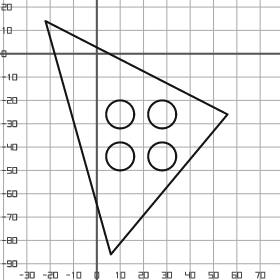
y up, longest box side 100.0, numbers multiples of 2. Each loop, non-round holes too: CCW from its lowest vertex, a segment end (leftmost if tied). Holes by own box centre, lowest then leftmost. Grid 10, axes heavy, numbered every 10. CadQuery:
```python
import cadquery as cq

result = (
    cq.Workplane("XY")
    .moveTo(6.0, -86.0)
    .lineTo(56.0, -26.0)
    .lineTo(-22.0, 14.0)
    .close()
    .moveTo(10.0, -44.0)
    .circle(6.0)
    .moveTo(28.0, -44.0)
    .circle(6.0)
    .moveTo(10.0, -26.0)
    .circle(6.0)
    .moveTo(28.0, -26.0)
    .circle(6.0)
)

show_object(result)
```